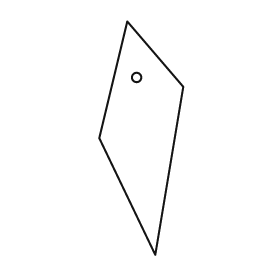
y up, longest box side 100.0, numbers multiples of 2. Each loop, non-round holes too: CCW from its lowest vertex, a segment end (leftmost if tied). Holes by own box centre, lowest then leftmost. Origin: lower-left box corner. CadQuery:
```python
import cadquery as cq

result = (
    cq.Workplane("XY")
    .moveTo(24.0, 0.0)
    .lineTo(36.0, 72.0)
    .lineTo(12.0, 100.0)
    .lineTo(0.0, 50.0)
    .close()
    .moveTo(16.0, 76.0)
    .circle(2.0)
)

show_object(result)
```